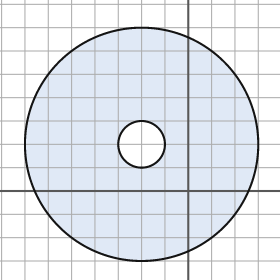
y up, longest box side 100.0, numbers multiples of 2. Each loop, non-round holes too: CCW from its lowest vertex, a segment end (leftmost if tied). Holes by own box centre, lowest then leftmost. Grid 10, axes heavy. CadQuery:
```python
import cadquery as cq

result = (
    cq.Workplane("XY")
    .moveTo(-20.0, 20.0)
    .circle(50.0)
    .moveTo(-20.0, 20.0)
    .circle(10.0)
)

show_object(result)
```